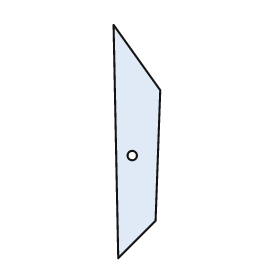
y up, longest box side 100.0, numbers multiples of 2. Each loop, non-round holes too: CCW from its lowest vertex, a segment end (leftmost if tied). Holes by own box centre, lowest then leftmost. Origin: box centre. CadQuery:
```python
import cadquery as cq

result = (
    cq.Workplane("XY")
    .moveTo(-8.0, -50.0)
    .lineTo(8.0, -34.0)
    .lineTo(10.0, 22.0)
    .lineTo(-10.0, 50.0)
    .close()
    .moveTo(-2.0, -6.0)
    .circle(2.0)
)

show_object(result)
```